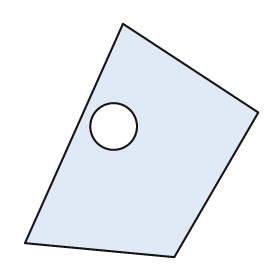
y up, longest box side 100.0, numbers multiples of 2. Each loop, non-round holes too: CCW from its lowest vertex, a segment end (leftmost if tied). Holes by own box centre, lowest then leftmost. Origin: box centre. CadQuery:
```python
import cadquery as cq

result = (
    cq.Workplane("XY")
    .moveTo(14.0, -50.0)
    .lineTo(50.0, 12.0)
    .lineTo(-8.0, 50.0)
    .lineTo(-50.0, -44.0)
    .close()
    .moveTo(-12.0, 6.0)
    .circle(10.0)
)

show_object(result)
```